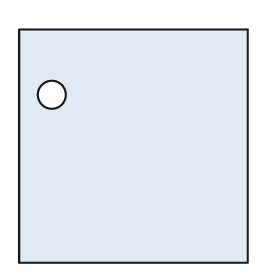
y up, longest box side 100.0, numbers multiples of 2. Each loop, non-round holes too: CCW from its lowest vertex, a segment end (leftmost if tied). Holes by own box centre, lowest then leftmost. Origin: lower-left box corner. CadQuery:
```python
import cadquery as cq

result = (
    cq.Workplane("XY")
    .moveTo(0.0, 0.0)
    .lineTo(98.0, 0.0)
    .lineTo(98.0, 100.0)
    .lineTo(0.0, 100.0)
    .close()
    .moveTo(14.0, 72.0)
    .circle(6.0)
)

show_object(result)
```